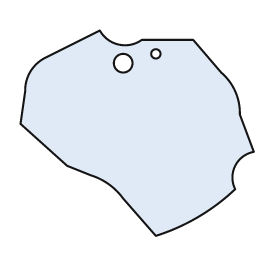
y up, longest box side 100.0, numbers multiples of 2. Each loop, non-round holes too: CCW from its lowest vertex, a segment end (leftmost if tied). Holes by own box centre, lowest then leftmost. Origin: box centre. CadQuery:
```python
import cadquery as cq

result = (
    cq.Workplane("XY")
    .moveTo(8.0, -44.0)
    .threePointArc((26.0, -36.0), (42.0, -24.0))
    .threePointArc((42.0, -14.0), (50.0, -8.0))
    .lineTo(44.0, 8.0)
    .threePointArc((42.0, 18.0), (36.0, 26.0))
    .lineTo(24.0, 40.0)
    .lineTo(2.0, 40.0)
    .threePointArc((-8.0, 38.0), (-16.0, 44.0))
    .lineTo(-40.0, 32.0)
    .threePointArc((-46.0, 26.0), (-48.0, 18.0))
    .lineTo(-50.0, 4.0)
    .lineTo(-30.0, -14.0)
    .lineTo(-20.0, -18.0)
    .threePointArc((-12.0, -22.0), (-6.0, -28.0))
    .close()
    .moveTo(-6.0, 30.0)
    .circle(4.0)
    .moveTo(8.0, 34.0)
    .circle(2.0)
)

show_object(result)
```